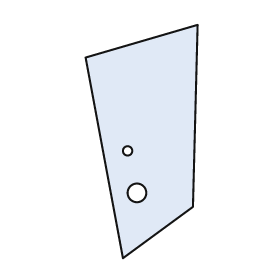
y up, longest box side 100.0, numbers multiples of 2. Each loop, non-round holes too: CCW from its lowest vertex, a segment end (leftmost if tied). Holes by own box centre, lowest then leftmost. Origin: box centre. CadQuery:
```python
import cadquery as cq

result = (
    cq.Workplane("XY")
    .moveTo(-8.0, -50.0)
    .lineTo(22.0, -28.0)
    .lineTo(24.0, 50.0)
    .lineTo(-24.0, 36.0)
    .close()
    .moveTo(-2.0, -22.0)
    .circle(4.0)
    .moveTo(-6.0, -4.0)
    .circle(2.0)
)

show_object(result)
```